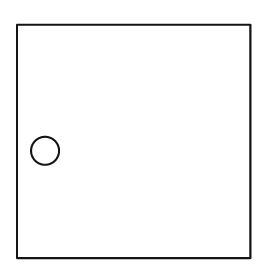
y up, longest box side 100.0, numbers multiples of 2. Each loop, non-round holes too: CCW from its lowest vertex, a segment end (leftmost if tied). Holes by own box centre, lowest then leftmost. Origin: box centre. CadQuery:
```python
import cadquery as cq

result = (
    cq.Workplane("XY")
    .moveTo(-50.0, -50.0)
    .lineTo(50.0, -50.0)
    .lineTo(50.0, 50.0)
    .lineTo(-50.0, 50.0)
    .close()
    .moveTo(-38.0, -4.0)
    .circle(6.0)
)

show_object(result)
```